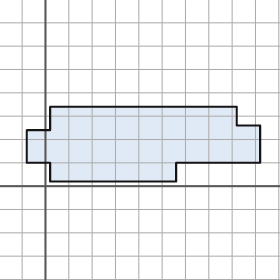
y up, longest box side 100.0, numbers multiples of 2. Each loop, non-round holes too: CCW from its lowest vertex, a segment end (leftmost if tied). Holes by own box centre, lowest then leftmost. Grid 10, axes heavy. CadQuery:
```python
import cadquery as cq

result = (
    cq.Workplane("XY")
    .moveTo(2.0, 2.0)
    .lineTo(56.0, 2.0)
    .lineTo(56.0, 10.0)
    .lineTo(92.0, 10.0)
    .lineTo(92.0, 26.0)
    .lineTo(82.0, 26.0)
    .lineTo(82.0, 34.0)
    .lineTo(2.0, 34.0)
    .lineTo(2.0, 24.0)
    .lineTo(-8.0, 24.0)
    .lineTo(-8.0, 10.0)
    .lineTo(2.0, 10.0)
    .close()
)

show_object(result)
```